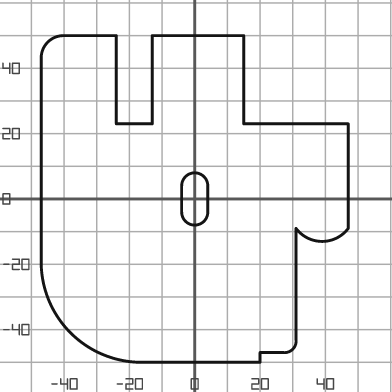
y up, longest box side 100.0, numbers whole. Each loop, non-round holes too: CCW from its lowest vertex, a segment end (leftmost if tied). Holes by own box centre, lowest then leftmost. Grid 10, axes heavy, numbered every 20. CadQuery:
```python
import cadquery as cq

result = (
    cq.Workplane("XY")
    .moveTo(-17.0, -50.0)
    .lineTo(20.0, -50.0)
    .lineTo(20.0, -47.0)
    .lineTo(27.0, -47.0)
    .threePointArc((30.0, -46.0), (31.0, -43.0))
    .lineTo(31.0, -9.0)
    .threePointArc((39.0, -13.0), (47.0, -9.0))
    .lineTo(47.0, 23.0)
    .lineTo(15.0, 23.0)
    .lineTo(15.0, 50.0)
    .lineTo(-13.0, 50.0)
    .lineTo(-13.0, 23.0)
    .lineTo(-24.0, 23.0)
    .lineTo(-24.0, 50.0)
    .lineTo(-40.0, 50.0)
    .threePointArc((-45.0, 48.0), (-47.0, 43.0))
    .lineTo(-47.0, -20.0)
    .threePointArc((-38.0, -41.0), (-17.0, -50.0))
    .close()
    .moveTo(-4.0, -4.0)
    .threePointArc((0.0, -8.0), (4.0, -4.0))
    .lineTo(4.0, 4.0)
    .threePointArc((0.0, 8.0), (-4.0, 4.0))
    .close()
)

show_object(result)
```